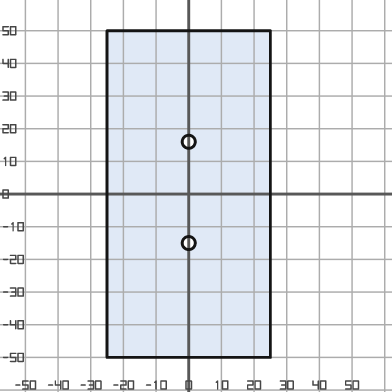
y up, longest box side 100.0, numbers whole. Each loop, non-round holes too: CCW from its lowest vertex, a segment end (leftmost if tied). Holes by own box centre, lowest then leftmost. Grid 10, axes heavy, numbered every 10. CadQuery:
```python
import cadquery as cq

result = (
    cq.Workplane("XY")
    .moveTo(-25.0, -50.0)
    .lineTo(25.0, -50.0)
    .lineTo(25.0, 50.0)
    .lineTo(-25.0, 50.0)
    .close()
    .moveTo(0.0, -15.0)
    .circle(2.0)
    .moveTo(0.0, 16.0)
    .circle(2.0)
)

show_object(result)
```